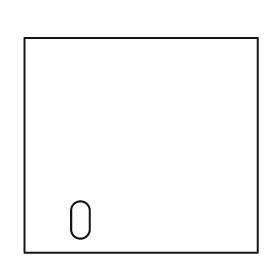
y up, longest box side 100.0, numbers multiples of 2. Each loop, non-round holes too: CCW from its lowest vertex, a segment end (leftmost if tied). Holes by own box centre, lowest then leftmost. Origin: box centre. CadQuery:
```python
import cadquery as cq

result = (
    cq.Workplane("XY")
    .moveTo(-50.0, -46.0)
    .lineTo(50.0, -46.0)
    .lineTo(50.0, 46.0)
    .lineTo(-50.0, 46.0)
    .close()
    .moveTo(-30.0, -36.0)
    .threePointArc((-26.0, -40.0), (-22.0, -36.0))
    .lineTo(-22.0, -28.0)
    .threePointArc((-26.0, -24.0), (-30.0, -28.0))
    .close()
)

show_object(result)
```